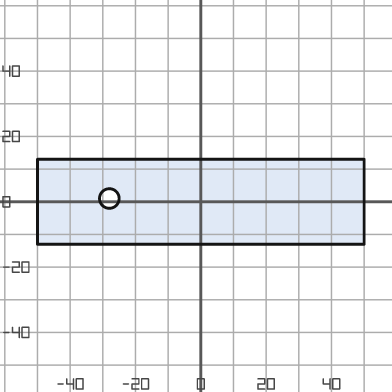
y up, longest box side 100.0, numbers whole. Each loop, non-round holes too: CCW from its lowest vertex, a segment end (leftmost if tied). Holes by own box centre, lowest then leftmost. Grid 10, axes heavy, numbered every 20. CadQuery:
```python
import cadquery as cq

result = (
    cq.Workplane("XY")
    .moveTo(-50.0, -13.0)
    .lineTo(50.0, -13.0)
    .lineTo(50.0, 13.0)
    .lineTo(-50.0, 13.0)
    .close()
    .moveTo(-28.0, 1.0)
    .circle(3.0)
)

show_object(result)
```